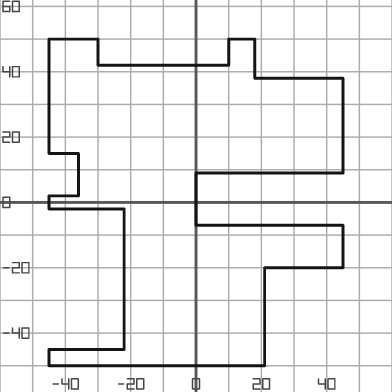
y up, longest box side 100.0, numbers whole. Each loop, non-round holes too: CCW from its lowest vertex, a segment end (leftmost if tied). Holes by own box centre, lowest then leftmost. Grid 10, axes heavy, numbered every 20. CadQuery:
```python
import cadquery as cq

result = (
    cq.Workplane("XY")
    .moveTo(-45.0, -50.0)
    .lineTo(21.0, -50.0)
    .lineTo(21.0, -20.0)
    .lineTo(45.0, -20.0)
    .lineTo(45.0, -7.0)
    .lineTo(0.0, -7.0)
    .lineTo(0.0, 9.0)
    .lineTo(45.0, 9.0)
    .lineTo(45.0, 38.0)
    .lineTo(18.0, 38.0)
    .lineTo(18.0, 50.0)
    .lineTo(10.0, 50.0)
    .lineTo(10.0, 42.0)
    .lineTo(-30.0, 42.0)
    .lineTo(-30.0, 50.0)
    .lineTo(-45.0, 50.0)
    .lineTo(-45.0, 15.0)
    .lineTo(-36.0, 15.0)
    .lineTo(-36.0, 2.0)
    .lineTo(-45.0, 2.0)
    .lineTo(-45.0, -2.0)
    .lineTo(-22.0, -2.0)
    .lineTo(-22.0, -45.0)
    .lineTo(-45.0, -45.0)
    .close()
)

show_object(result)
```